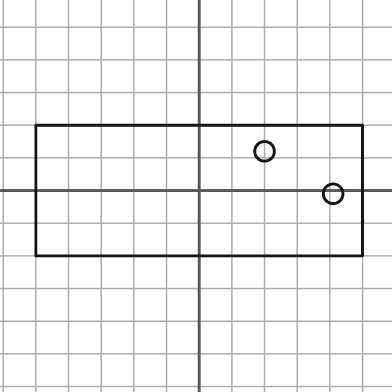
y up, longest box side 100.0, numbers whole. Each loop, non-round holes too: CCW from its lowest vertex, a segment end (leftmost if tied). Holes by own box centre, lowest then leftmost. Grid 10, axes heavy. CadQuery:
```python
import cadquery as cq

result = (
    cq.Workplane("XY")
    .moveTo(-50.0, -20.0)
    .lineTo(50.0, -20.0)
    .lineTo(50.0, 20.0)
    .lineTo(-50.0, 20.0)
    .close()
    .moveTo(41.0, -1.0)
    .circle(3.0)
    .moveTo(20.0, 12.0)
    .circle(3.0)
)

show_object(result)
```